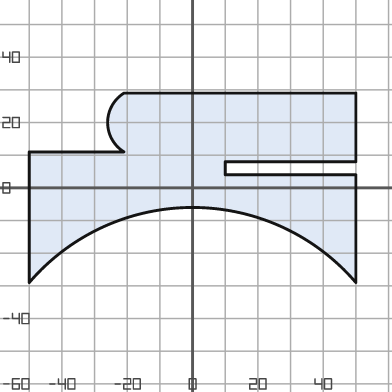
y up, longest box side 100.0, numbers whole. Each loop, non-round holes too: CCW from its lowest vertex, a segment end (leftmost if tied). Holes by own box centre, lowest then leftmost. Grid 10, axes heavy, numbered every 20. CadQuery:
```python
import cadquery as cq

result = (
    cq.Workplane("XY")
    .moveTo(-50.0, -29.0)
    .threePointArc((0.0, -6.0), (50.0, -29.0))
    .lineTo(50.0, 4.0)
    .lineTo(10.0, 4.0)
    .lineTo(10.0, 8.0)
    .lineTo(50.0, 8.0)
    .lineTo(50.0, 29.0)
    .lineTo(-21.0, 29.0)
    .threePointArc((-26.0, 20.0), (-21.0, 11.0))
    .lineTo(-50.0, 11.0)
    .close()
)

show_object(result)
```